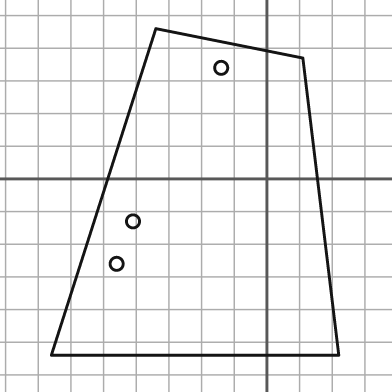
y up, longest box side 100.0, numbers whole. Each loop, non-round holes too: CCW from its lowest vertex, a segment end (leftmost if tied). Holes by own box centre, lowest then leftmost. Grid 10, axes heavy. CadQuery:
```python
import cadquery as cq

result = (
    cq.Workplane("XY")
    .moveTo(-66.0, -54.0)
    .lineTo(22.0, -54.0)
    .lineTo(11.0, 37.0)
    .lineTo(-34.0, 46.0)
    .close()
    .moveTo(-46.0, -26.0)
    .circle(2.0)
    .moveTo(-41.0, -13.0)
    .circle(2.0)
    .moveTo(-14.0, 34.0)
    .circle(2.0)
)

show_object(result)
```